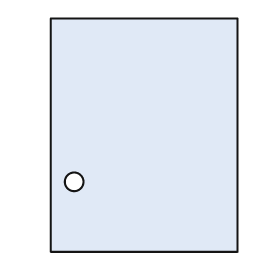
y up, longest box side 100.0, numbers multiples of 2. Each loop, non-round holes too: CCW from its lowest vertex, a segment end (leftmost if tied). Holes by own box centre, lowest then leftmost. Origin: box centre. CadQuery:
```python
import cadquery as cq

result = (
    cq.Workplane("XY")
    .moveTo(-40.0, -50.0)
    .lineTo(40.0, -50.0)
    .lineTo(40.0, 50.0)
    .lineTo(-40.0, 50.0)
    .close()
    .moveTo(-30.0, -20.0)
    .circle(4.0)
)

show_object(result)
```